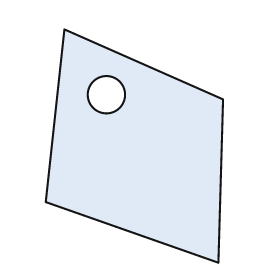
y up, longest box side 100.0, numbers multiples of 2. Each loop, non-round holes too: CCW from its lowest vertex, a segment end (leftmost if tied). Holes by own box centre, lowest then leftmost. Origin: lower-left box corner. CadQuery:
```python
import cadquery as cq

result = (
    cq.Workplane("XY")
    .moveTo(74.0, 0.0)
    .lineTo(76.0, 70.0)
    .lineTo(8.0, 100.0)
    .lineTo(0.0, 26.0)
    .close()
    .moveTo(26.0, 72.0)
    .circle(8.0)
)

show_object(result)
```